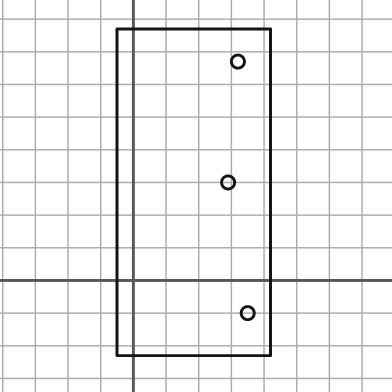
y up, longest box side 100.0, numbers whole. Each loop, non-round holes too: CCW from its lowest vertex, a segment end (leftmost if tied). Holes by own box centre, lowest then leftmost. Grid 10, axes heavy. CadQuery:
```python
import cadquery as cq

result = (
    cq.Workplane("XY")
    .moveTo(-5.0, -23.0)
    .lineTo(42.0, -23.0)
    .lineTo(42.0, 77.0)
    .lineTo(-5.0, 77.0)
    .close()
    .moveTo(35.0, -10.0)
    .circle(2.0)
    .moveTo(29.0, 30.0)
    .circle(2.0)
    .moveTo(32.0, 67.0)
    .circle(2.0)
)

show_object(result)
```